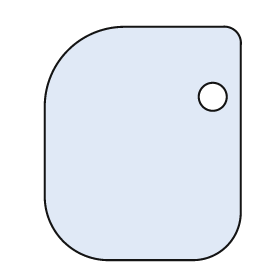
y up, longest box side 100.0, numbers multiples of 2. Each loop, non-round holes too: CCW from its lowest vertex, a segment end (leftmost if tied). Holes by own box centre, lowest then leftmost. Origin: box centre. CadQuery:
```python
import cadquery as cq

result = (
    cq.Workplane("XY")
    .moveTo(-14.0, -50.0)
    .lineTo(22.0, -50.0)
    .threePointArc((36.0, -44.0), (42.0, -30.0))
    .lineTo(42.0, 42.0)
    .threePointArc((40.0, 48.0), (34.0, 50.0))
    .lineTo(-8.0, 50.0)
    .threePointArc((-32.0, 40.0), (-42.0, 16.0))
    .lineTo(-42.0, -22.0)
    .threePointArc((-34.0, -42.0), (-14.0, -50.0))
    .close()
    .moveTo(30.0, 20.0)
    .circle(6.0)
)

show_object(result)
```